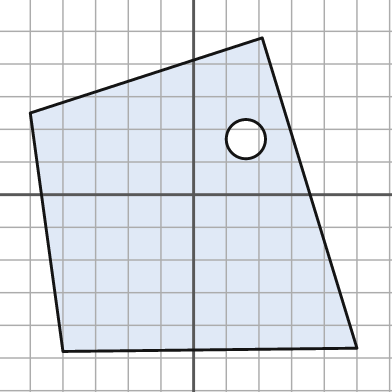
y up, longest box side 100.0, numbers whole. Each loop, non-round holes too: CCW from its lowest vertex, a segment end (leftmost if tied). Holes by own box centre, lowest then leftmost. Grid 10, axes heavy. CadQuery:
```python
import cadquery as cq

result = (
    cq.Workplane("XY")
    .moveTo(-40.0, -48.0)
    .lineTo(50.0, -47.0)
    .lineTo(21.0, 48.0)
    .lineTo(-50.0, 25.0)
    .close()
    .moveTo(16.0, 17.0)
    .circle(6.0)
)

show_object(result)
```